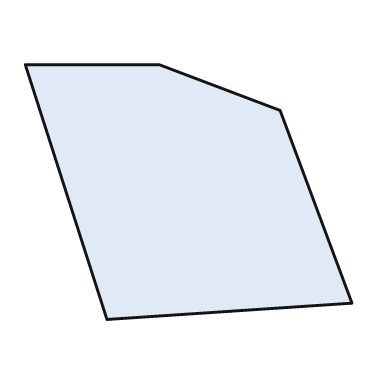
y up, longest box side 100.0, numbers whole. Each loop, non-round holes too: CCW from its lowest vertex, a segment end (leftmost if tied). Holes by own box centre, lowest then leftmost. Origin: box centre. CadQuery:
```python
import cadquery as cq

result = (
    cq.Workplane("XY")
    .moveTo(-25.0, -39.0)
    .lineTo(50.0, -34.0)
    .lineTo(28.0, 25.0)
    .lineTo(-9.0, 39.0)
    .lineTo(-50.0, 39.0)
    .close()
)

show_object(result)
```